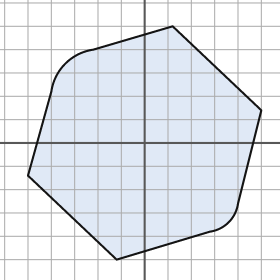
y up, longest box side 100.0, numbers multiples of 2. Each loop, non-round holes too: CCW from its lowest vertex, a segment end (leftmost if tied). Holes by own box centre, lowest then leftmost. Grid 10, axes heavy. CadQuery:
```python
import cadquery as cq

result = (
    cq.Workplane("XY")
    .moveTo(-12.0, -50.0)
    .lineTo(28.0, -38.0)
    .threePointArc((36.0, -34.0), (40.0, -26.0))
    .lineTo(50.0, 14.0)
    .lineTo(12.0, 50.0)
    .lineTo(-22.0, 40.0)
    .threePointArc((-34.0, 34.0), (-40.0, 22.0))
    .lineTo(-50.0, -14.0)
    .close()
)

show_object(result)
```